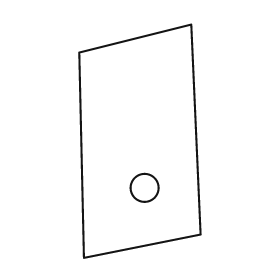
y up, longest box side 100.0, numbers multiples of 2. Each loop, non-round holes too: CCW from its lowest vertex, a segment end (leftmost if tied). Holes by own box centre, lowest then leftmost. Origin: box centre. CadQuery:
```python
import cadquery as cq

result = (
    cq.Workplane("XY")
    .moveTo(-24.0, -50.0)
    .lineTo(26.0, -40.0)
    .lineTo(22.0, 50.0)
    .lineTo(-26.0, 38.0)
    .close()
    .moveTo(2.0, -20.0)
    .circle(6.0)
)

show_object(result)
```